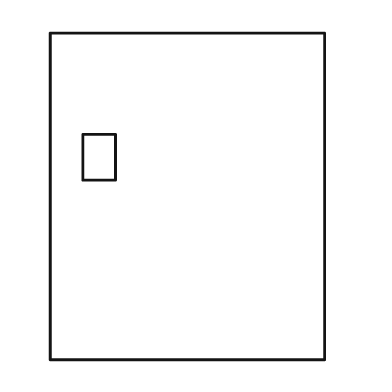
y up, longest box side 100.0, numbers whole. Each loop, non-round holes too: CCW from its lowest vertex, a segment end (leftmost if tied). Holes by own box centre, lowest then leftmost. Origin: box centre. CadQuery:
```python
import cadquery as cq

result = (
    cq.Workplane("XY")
    .moveTo(-42.0, -50.0)
    .lineTo(42.0, -50.0)
    .lineTo(42.0, 50.0)
    .lineTo(-42.0, 50.0)
    .close()
    .moveTo(-32.0, 5.0)
    .lineTo(-22.0, 5.0)
    .lineTo(-22.0, 19.0)
    .lineTo(-32.0, 19.0)
    .close()
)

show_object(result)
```